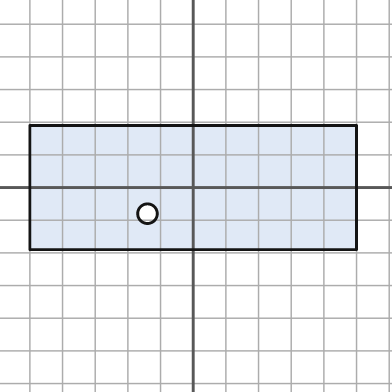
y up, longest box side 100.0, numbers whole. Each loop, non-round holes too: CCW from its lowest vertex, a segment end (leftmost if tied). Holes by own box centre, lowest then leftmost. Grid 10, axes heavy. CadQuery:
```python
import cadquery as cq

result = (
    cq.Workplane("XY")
    .moveTo(-50.0, -19.0)
    .lineTo(50.0, -19.0)
    .lineTo(50.0, 19.0)
    .lineTo(-50.0, 19.0)
    .close()
    .moveTo(-14.0, -8.0)
    .circle(3.0)
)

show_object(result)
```